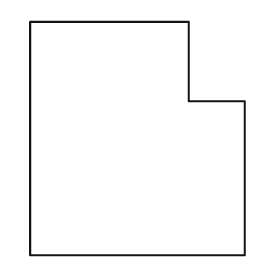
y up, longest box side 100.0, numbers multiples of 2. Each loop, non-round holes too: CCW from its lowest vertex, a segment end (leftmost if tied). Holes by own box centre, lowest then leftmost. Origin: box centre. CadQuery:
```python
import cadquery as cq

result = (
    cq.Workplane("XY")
    .moveTo(-46.0, -50.0)
    .lineTo(46.0, -50.0)
    .lineTo(46.0, 16.0)
    .lineTo(22.0, 16.0)
    .lineTo(22.0, 50.0)
    .lineTo(-46.0, 50.0)
    .close()
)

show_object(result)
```